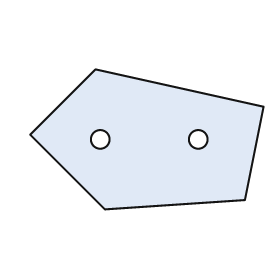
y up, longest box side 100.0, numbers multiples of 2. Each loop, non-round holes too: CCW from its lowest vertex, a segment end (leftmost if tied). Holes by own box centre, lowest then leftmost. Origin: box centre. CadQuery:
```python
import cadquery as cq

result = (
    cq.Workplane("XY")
    .moveTo(-18.0, -30.0)
    .lineTo(42.0, -26.0)
    .lineTo(50.0, 14.0)
    .lineTo(-22.0, 30.0)
    .lineTo(-50.0, 2.0)
    .close()
    .moveTo(-20.0, 0.0)
    .circle(4.0)
    .moveTo(22.0, 0.0)
    .circle(4.0)
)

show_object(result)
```